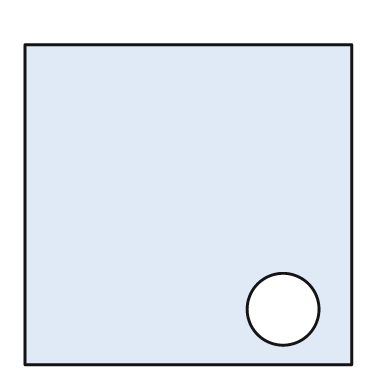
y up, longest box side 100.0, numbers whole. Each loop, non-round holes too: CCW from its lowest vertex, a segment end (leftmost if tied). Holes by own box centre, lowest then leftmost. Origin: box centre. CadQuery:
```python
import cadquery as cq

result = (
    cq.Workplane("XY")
    .moveTo(-50.0, -49.0)
    .lineTo(50.0, -49.0)
    .lineTo(50.0, 49.0)
    .lineTo(-50.0, 49.0)
    .close()
    .moveTo(29.0, -32.0)
    .circle(11.0)
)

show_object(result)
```